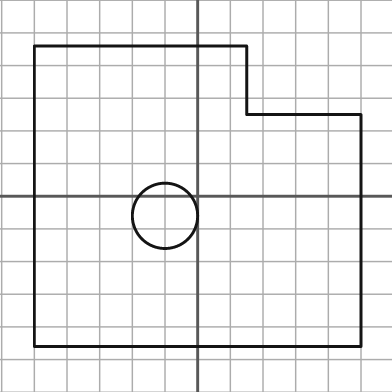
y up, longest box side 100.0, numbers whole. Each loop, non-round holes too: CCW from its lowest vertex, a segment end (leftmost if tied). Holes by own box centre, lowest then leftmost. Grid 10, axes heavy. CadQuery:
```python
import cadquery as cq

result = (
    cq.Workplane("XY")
    .moveTo(-50.0, -46.0)
    .lineTo(50.0, -46.0)
    .lineTo(50.0, 25.0)
    .lineTo(15.0, 25.0)
    .lineTo(15.0, 46.0)
    .lineTo(-50.0, 46.0)
    .close()
    .moveTo(-10.0, -6.0)
    .circle(10.0)
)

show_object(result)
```